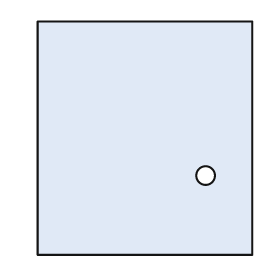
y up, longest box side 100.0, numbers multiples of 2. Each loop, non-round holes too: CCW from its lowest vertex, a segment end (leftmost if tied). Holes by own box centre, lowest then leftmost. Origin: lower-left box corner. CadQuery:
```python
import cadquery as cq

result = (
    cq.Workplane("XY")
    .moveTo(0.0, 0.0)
    .lineTo(92.0, 0.0)
    .lineTo(92.0, 100.0)
    .lineTo(0.0, 100.0)
    .close()
    .moveTo(72.0, 34.0)
    .circle(4.0)
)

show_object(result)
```